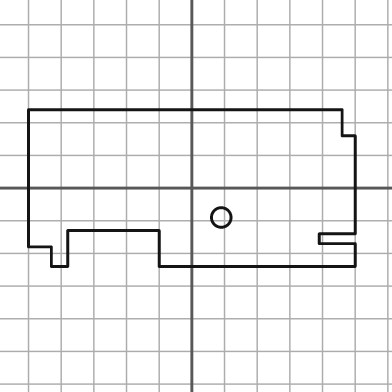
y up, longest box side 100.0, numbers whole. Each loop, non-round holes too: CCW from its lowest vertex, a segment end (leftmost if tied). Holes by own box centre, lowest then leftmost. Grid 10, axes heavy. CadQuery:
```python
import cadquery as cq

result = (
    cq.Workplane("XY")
    .moveTo(-43.0, -24.0)
    .lineTo(-38.0, -24.0)
    .lineTo(-38.0, -13.0)
    .lineTo(-10.0, -13.0)
    .lineTo(-10.0, -24.0)
    .lineTo(50.0, -24.0)
    .lineTo(50.0, -17.0)
    .lineTo(39.0, -17.0)
    .lineTo(39.0, -14.0)
    .lineTo(50.0, -14.0)
    .lineTo(50.0, 16.0)
    .lineTo(46.0, 16.0)
    .lineTo(46.0, 24.0)
    .lineTo(-50.0, 24.0)
    .lineTo(-50.0, -18.0)
    .lineTo(-43.0, -18.0)
    .close()
    .moveTo(9.0, -9.0)
    .circle(3.0)
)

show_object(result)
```